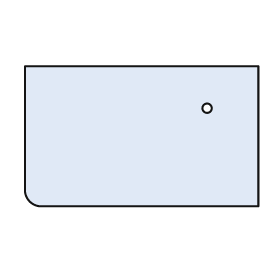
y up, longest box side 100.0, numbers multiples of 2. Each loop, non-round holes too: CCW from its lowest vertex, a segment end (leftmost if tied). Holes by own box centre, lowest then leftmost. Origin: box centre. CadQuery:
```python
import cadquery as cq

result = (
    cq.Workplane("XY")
    .moveTo(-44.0, -30.0)
    .lineTo(50.0, -30.0)
    .lineTo(50.0, 30.0)
    .lineTo(-50.0, 30.0)
    .lineTo(-50.0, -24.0)
    .threePointArc((-48.0, -28.0), (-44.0, -30.0))
    .close()
    .moveTo(28.0, 12.0)
    .circle(2.0)
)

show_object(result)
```